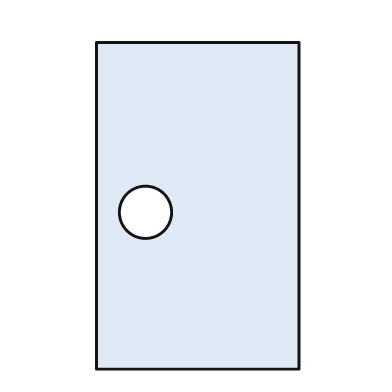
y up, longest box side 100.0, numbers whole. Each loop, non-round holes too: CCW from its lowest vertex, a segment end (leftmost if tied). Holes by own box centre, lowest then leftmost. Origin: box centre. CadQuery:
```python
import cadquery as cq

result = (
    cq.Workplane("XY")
    .moveTo(-31.0, -50.0)
    .lineTo(31.0, -50.0)
    .lineTo(31.0, 50.0)
    .lineTo(-31.0, 50.0)
    .close()
    .moveTo(-16.0, -2.0)
    .circle(8.0)
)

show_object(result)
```